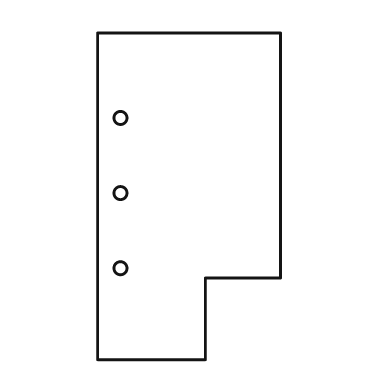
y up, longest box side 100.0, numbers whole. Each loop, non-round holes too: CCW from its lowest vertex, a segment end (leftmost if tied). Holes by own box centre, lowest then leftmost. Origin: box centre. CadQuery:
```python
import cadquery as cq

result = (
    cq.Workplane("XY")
    .moveTo(-28.0, -50.0)
    .lineTo(5.0, -50.0)
    .lineTo(5.0, -25.0)
    .lineTo(28.0, -25.0)
    .lineTo(28.0, 50.0)
    .lineTo(-28.0, 50.0)
    .close()
    .moveTo(-21.0, -22.0)
    .circle(2.0)
    .moveTo(-21.0, 1.0)
    .circle(2.0)
    .moveTo(-21.0, 24.0)
    .circle(2.0)
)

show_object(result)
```